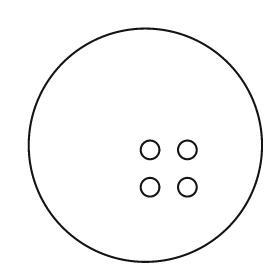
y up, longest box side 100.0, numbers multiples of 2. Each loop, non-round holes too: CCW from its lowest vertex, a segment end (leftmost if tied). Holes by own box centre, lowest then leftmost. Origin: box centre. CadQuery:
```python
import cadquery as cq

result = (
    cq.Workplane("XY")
    .moveTo(0.0, 0.0)
    .circle(50.0)
    .moveTo(2.0, -18.0)
    .circle(4.0)
    .moveTo(18.0, -18.0)
    .circle(4.0)
    .moveTo(2.0, -2.0)
    .circle(4.0)
    .moveTo(18.0, -2.0)
    .circle(4.0)
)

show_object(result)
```